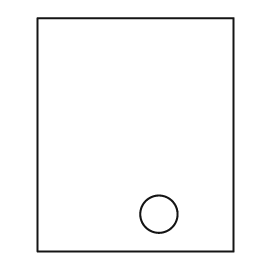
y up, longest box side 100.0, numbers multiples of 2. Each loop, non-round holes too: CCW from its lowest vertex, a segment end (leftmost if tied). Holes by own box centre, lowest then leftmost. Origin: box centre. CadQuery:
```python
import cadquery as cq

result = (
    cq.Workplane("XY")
    .moveTo(-42.0, -50.0)
    .lineTo(42.0, -50.0)
    .lineTo(42.0, 50.0)
    .lineTo(-42.0, 50.0)
    .close()
    .moveTo(10.0, -34.0)
    .circle(8.0)
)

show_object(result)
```